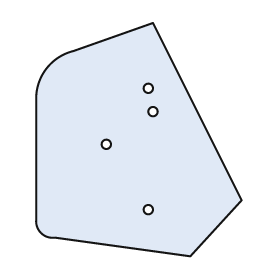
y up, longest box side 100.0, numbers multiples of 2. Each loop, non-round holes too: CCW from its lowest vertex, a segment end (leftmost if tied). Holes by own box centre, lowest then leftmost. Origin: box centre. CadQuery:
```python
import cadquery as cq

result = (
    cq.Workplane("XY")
    .moveTo(22.0, -50.0)
    .lineTo(44.0, -26.0)
    .lineTo(6.0, 50.0)
    .lineTo(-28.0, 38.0)
    .threePointArc((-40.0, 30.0), (-44.0, 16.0))
    .lineTo(-44.0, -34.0)
    .threePointArc((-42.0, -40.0), (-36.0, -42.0))
    .close()
    .moveTo(4.0, -30.0)
    .circle(2.0)
    .moveTo(-14.0, -2.0)
    .circle(2.0)
    .moveTo(6.0, 12.0)
    .circle(2.0)
    .moveTo(4.0, 22.0)
    .circle(2.0)
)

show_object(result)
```